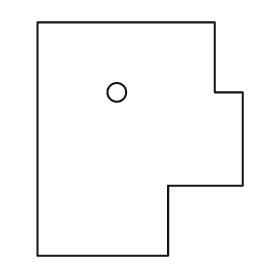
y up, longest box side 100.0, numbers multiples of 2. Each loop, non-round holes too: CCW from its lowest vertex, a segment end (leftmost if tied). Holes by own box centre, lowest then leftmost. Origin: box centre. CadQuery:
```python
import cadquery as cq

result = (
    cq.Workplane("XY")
    .moveTo(-44.0, -50.0)
    .lineTo(12.0, -50.0)
    .lineTo(12.0, -20.0)
    .lineTo(44.0, -20.0)
    .lineTo(44.0, 20.0)
    .lineTo(32.0, 20.0)
    .lineTo(32.0, 50.0)
    .lineTo(-44.0, 50.0)
    .close()
    .moveTo(-10.0, 20.0)
    .circle(4.0)
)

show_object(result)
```